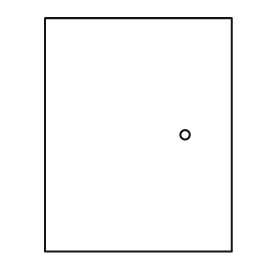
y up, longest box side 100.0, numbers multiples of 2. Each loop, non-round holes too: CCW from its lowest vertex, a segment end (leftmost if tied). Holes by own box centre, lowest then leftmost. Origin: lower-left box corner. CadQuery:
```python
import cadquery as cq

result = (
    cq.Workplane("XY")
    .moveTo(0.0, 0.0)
    .lineTo(80.0, 0.0)
    .lineTo(80.0, 100.0)
    .lineTo(0.0, 100.0)
    .close()
    .moveTo(60.0, 50.0)
    .circle(2.0)
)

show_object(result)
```